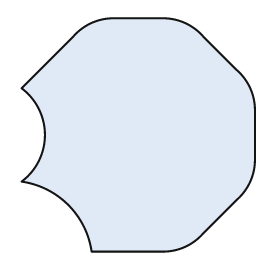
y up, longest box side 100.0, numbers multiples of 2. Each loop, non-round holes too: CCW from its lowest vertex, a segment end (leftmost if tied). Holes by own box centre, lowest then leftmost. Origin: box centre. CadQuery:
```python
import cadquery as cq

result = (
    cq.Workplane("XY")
    .moveTo(-20.0, -50.0)
    .lineTo(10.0, -50.0)
    .threePointArc((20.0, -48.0), (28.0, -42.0))
    .lineTo(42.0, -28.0)
    .threePointArc((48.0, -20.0), (50.0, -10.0))
    .lineTo(50.0, 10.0)
    .threePointArc((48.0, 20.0), (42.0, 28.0))
    .lineTo(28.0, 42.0)
    .threePointArc((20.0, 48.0), (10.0, 50.0))
    .lineTo(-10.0, 50.0)
    .threePointArc((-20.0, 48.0), (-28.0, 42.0))
    .lineTo(-50.0, 20.0)
    .threePointArc((-40.0, 0.0), (-50.0, -20.0))
    .threePointArc((-30.0, -30.0), (-20.0, -50.0))
    .close()
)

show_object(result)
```